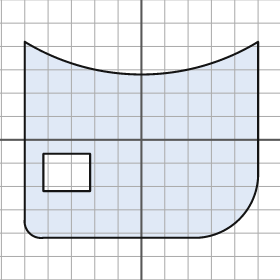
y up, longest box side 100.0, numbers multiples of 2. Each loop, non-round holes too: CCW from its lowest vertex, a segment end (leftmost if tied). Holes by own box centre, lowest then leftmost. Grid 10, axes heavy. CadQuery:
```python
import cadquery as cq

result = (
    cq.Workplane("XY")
    .moveTo(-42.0, -42.0)
    .lineTo(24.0, -42.0)
    .threePointArc((42.0, -34.0), (50.0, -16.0))
    .lineTo(50.0, 42.0)
    .threePointArc((0.0, 28.0), (-50.0, 42.0))
    .lineTo(-50.0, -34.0)
    .threePointArc((-48.0, -40.0), (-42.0, -42.0))
    .close()
    .moveTo(-42.0, -22.0)
    .lineTo(-22.0, -22.0)
    .lineTo(-22.0, -6.0)
    .lineTo(-42.0, -6.0)
    .close()
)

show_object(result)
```